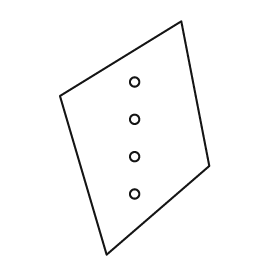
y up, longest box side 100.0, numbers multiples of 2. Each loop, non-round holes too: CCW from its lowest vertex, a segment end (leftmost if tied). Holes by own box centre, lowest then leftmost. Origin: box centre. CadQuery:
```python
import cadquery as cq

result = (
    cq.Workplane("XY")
    .moveTo(-12.0, -50.0)
    .lineTo(32.0, -12.0)
    .lineTo(20.0, 50.0)
    .lineTo(-32.0, 18.0)
    .close()
    .moveTo(0.0, -24.0)
    .circle(2.0)
    .moveTo(0.0, -8.0)
    .circle(2.0)
    .moveTo(0.0, 8.0)
    .circle(2.0)
    .moveTo(0.0, 24.0)
    .circle(2.0)
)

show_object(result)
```